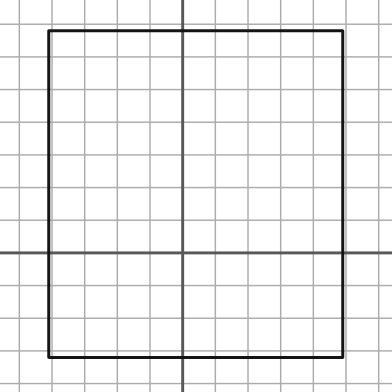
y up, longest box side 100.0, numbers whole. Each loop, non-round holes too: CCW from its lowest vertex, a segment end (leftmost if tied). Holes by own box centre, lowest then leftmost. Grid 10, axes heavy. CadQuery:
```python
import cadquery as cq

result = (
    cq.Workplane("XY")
    .moveTo(-41.0, -32.0)
    .lineTo(49.0, -32.0)
    .lineTo(49.0, 68.0)
    .lineTo(-41.0, 68.0)
    .close()
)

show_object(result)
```